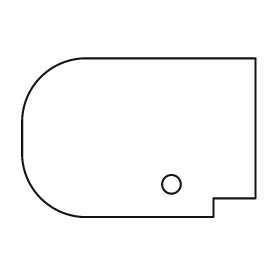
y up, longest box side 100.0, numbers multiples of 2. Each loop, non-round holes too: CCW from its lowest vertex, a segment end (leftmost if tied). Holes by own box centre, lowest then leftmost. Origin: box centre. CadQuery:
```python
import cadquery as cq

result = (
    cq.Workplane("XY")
    .moveTo(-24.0, -34.0)
    .lineTo(32.0, -34.0)
    .lineTo(32.0, -26.0)
    .lineTo(50.0, -26.0)
    .lineTo(50.0, 34.0)
    .lineTo(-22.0, 34.0)
    .threePointArc((-42.0, 26.0), (-50.0, 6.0))
    .lineTo(-50.0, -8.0)
    .threePointArc((-42.0, -26.0), (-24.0, -34.0))
    .close()
    .moveTo(14.0, -20.0)
    .circle(4.0)
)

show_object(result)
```